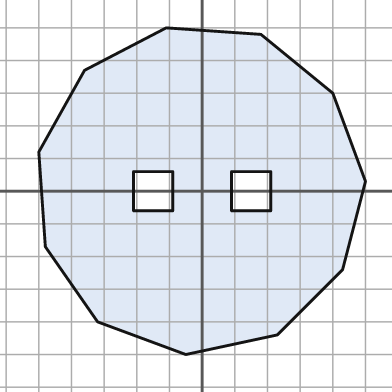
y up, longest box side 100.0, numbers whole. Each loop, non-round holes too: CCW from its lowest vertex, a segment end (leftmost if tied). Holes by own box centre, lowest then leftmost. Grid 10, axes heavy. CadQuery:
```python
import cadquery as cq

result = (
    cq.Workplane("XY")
    .moveTo(-5.0, -50.0)
    .lineTo(23.0, -44.0)
    .lineTo(43.0, -24.0)
    .lineTo(50.0, 3.0)
    .lineTo(40.0, 30.0)
    .lineTo(18.0, 48.0)
    .lineTo(-11.0, 50.0)
    .lineTo(-36.0, 37.0)
    .lineTo(-50.0, 12.0)
    .lineTo(-48.0, -17.0)
    .lineTo(-32.0, -40.0)
    .close()
    .moveTo(-21.0, -6.0)
    .lineTo(-9.0, -6.0)
    .lineTo(-9.0, 6.0)
    .lineTo(-21.0, 6.0)
    .close()
    .moveTo(9.0, -6.0)
    .lineTo(21.0, -6.0)
    .lineTo(21.0, 6.0)
    .lineTo(9.0, 6.0)
    .close()
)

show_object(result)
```